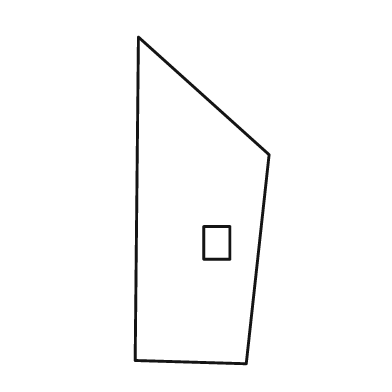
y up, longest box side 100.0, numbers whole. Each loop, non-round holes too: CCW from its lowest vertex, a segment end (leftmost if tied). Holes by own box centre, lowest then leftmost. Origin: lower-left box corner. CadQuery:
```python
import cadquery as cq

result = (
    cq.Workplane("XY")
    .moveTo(34.0, 0.0)
    .lineTo(41.0, 64.0)
    .lineTo(1.0, 100.0)
    .lineTo(0.0, 1.0)
    .close()
    .moveTo(21.0, 32.0)
    .lineTo(29.0, 32.0)
    .lineTo(29.0, 42.0)
    .lineTo(21.0, 42.0)
    .close()
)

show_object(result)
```